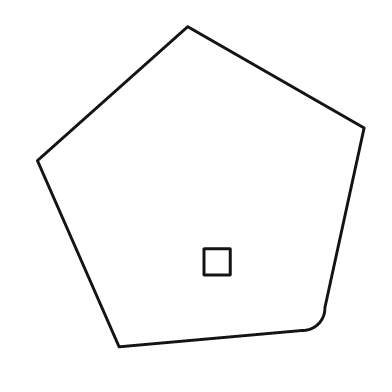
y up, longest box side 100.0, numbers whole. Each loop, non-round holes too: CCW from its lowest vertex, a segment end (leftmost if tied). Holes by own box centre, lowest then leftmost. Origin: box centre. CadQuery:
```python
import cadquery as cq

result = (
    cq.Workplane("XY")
    .moveTo(-25.0, -49.0)
    .lineTo(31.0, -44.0)
    .threePointArc((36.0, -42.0), (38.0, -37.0))
    .lineTo(50.0, 18.0)
    .lineTo(-4.0, 49.0)
    .lineTo(-50.0, 8.0)
    .close()
    .moveTo(1.0, -27.0)
    .lineTo(9.0, -27.0)
    .lineTo(9.0, -19.0)
    .lineTo(1.0, -19.0)
    .close()
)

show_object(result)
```